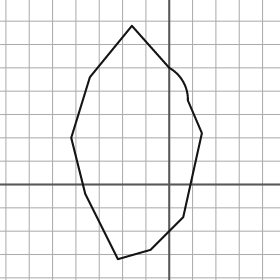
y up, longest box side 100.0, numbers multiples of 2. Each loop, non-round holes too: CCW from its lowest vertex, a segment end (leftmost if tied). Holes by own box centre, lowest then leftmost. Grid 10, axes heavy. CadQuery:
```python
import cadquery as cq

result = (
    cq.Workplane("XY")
    .moveTo(-22.0, -32.0)
    .lineTo(-8.0, -28.0)
    .lineTo(6.0, -14.0)
    .lineTo(14.0, 22.0)
    .lineTo(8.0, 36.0)
    .threePointArc((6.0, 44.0), (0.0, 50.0))
    .lineTo(-16.0, 68.0)
    .lineTo(-34.0, 46.0)
    .lineTo(-42.0, 20.0)
    .lineTo(-36.0, -4.0)
    .close()
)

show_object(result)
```